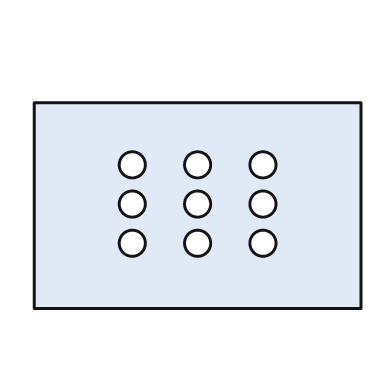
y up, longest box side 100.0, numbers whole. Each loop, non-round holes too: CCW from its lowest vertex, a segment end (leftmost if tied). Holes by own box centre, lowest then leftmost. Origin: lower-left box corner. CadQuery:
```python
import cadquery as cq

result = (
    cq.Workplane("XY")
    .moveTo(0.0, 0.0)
    .lineTo(100.0, 0.0)
    .lineTo(100.0, 63.0)
    .lineTo(0.0, 63.0)
    .close()
    .moveTo(30.0, 20.0)
    .circle(4.0)
    .moveTo(50.0, 20.0)
    .circle(4.0)
    .moveTo(70.0, 20.0)
    .circle(4.0)
    .moveTo(30.0, 32.0)
    .circle(4.0)
    .moveTo(50.0, 32.0)
    .circle(4.0)
    .moveTo(70.0, 32.0)
    .circle(4.0)
    .moveTo(30.0, 44.0)
    .circle(4.0)
    .moveTo(50.0, 44.0)
    .circle(4.0)
    .moveTo(70.0, 44.0)
    .circle(4.0)
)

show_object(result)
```